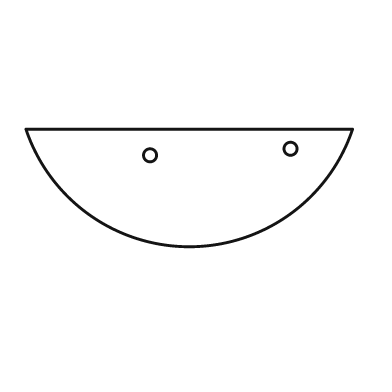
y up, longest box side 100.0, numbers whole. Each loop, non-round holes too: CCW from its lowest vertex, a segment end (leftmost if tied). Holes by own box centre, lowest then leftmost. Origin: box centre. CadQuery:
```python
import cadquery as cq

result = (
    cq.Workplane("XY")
    .moveTo(-50.0, 18.0)
    .threePointArc((0.0, -18.0), (50.0, 18.0))
    .close()
    .moveTo(-12.0, 10.0)
    .circle(2.0)
    .moveTo(31.0, 12.0)
    .circle(2.0)
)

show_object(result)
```